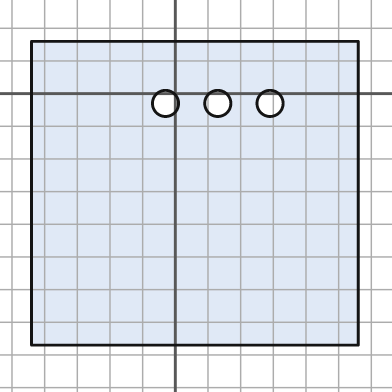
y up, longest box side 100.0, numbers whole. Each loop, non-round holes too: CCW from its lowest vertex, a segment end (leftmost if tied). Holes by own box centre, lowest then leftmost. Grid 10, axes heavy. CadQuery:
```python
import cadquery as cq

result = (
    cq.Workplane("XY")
    .moveTo(-44.0, -77.0)
    .lineTo(56.0, -77.0)
    .lineTo(56.0, 16.0)
    .lineTo(-44.0, 16.0)
    .close()
    .moveTo(-3.0, -3.0)
    .circle(4.0)
    .moveTo(13.0, -3.0)
    .circle(4.0)
    .moveTo(29.0, -3.0)
    .circle(4.0)
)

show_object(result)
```